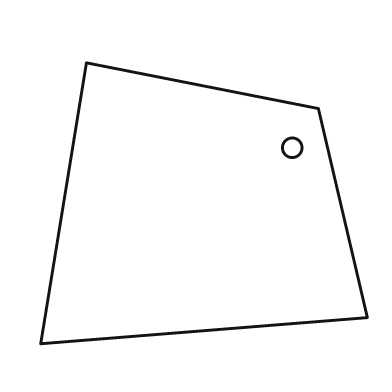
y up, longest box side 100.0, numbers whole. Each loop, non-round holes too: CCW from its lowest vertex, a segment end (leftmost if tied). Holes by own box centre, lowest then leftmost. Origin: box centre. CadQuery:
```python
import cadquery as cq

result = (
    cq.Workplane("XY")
    .moveTo(-50.0, -43.0)
    .lineTo(50.0, -35.0)
    .lineTo(35.0, 29.0)
    .lineTo(-36.0, 43.0)
    .close()
    .moveTo(27.0, 17.0)
    .circle(3.0)
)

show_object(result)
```